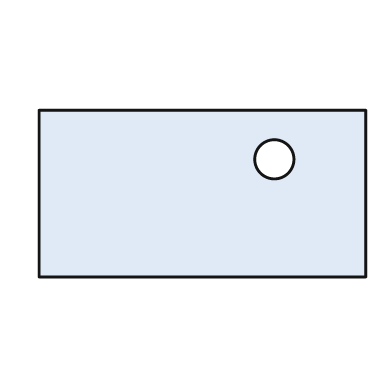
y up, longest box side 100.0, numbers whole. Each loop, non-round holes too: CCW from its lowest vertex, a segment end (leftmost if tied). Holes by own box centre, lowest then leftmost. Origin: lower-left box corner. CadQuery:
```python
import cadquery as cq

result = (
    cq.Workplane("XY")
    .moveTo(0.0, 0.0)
    .lineTo(100.0, 0.0)
    .lineTo(100.0, 51.0)
    .lineTo(0.0, 51.0)
    .close()
    .moveTo(72.0, 36.0)
    .circle(6.0)
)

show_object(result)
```